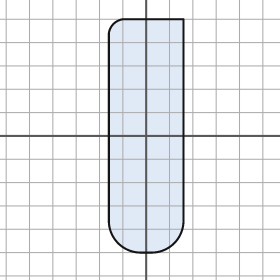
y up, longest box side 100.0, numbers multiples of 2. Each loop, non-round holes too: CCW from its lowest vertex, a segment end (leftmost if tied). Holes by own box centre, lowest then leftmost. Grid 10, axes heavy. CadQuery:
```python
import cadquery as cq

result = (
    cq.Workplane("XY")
    .moveTo(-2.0, -50.0)
    .lineTo(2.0, -50.0)
    .threePointArc((12.0, -46.0), (16.0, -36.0))
    .lineTo(16.0, 50.0)
    .lineTo(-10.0, 50.0)
    .threePointArc((-14.0, 48.0), (-16.0, 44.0))
    .lineTo(-16.0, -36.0)
    .threePointArc((-12.0, -46.0), (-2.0, -50.0))
    .close()
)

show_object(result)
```